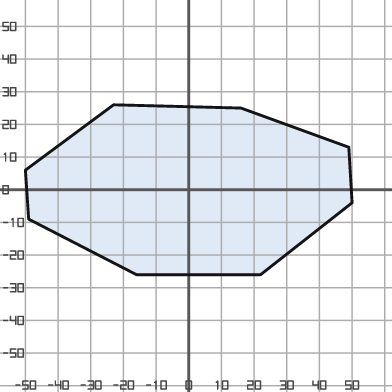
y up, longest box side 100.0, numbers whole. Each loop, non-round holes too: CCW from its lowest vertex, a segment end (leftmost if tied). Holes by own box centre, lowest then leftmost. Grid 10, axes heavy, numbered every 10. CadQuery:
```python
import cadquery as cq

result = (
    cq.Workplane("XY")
    .moveTo(-16.0, -26.0)
    .lineTo(22.0, -26.0)
    .lineTo(50.0, -4.0)
    .lineTo(49.0, 13.0)
    .lineTo(16.0, 25.0)
    .lineTo(-23.0, 26.0)
    .lineTo(-50.0, 6.0)
    .lineTo(-49.0, -9.0)
    .close()
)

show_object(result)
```